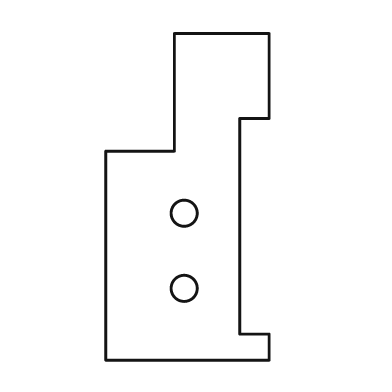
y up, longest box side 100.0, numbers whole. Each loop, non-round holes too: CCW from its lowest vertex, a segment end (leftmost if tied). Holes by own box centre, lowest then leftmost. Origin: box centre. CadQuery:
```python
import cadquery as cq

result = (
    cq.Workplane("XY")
    .moveTo(-25.0, -50.0)
    .lineTo(25.0, -50.0)
    .lineTo(25.0, -42.0)
    .lineTo(16.0, -42.0)
    .lineTo(16.0, 24.0)
    .lineTo(25.0, 24.0)
    .lineTo(25.0, 50.0)
    .lineTo(-4.0, 50.0)
    .lineTo(-4.0, 14.0)
    .lineTo(-25.0, 14.0)
    .close()
    .moveTo(-1.0, -28.0)
    .circle(4.0)
    .moveTo(-1.0, -5.0)
    .circle(4.0)
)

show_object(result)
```